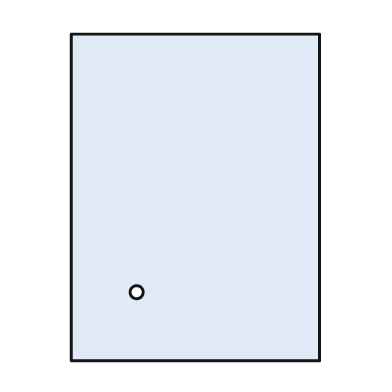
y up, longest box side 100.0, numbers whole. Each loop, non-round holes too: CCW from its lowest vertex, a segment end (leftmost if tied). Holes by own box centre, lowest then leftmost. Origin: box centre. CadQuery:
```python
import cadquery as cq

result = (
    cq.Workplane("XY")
    .moveTo(-38.0, -50.0)
    .lineTo(38.0, -50.0)
    .lineTo(38.0, 50.0)
    .lineTo(-38.0, 50.0)
    .close()
    .moveTo(-18.0, -29.0)
    .circle(2.0)
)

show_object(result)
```